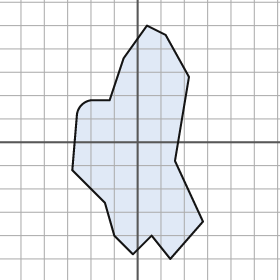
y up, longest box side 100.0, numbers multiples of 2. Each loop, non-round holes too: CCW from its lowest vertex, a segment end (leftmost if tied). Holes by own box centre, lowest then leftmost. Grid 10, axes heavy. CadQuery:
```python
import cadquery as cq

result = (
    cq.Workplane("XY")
    .moveTo(14.0, -50.0)
    .lineTo(28.0, -34.0)
    .lineTo(16.0, -8.0)
    .lineTo(22.0, 28.0)
    .lineTo(12.0, 46.0)
    .lineTo(4.0, 50.0)
    .lineTo(-6.0, 36.0)
    .lineTo(-12.0, 18.0)
    .lineTo(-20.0, 18.0)
    .threePointArc((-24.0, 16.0), (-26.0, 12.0))
    .lineTo(-28.0, -12.0)
    .lineTo(-14.0, -26.0)
    .lineTo(-10.0, -40.0)
    .lineTo(-2.0, -48.0)
    .lineTo(6.0, -40.0)
    .close()
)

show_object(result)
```